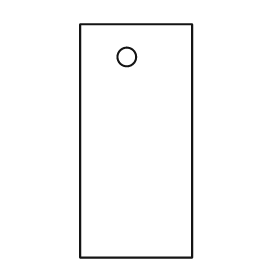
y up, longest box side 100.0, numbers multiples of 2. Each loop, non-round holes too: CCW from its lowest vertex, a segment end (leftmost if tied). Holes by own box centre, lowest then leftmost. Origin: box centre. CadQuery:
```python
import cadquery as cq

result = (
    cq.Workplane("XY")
    .moveTo(-24.0, -50.0)
    .lineTo(24.0, -50.0)
    .lineTo(24.0, 50.0)
    .lineTo(-24.0, 50.0)
    .close()
    .moveTo(-4.0, 36.0)
    .circle(4.0)
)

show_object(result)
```